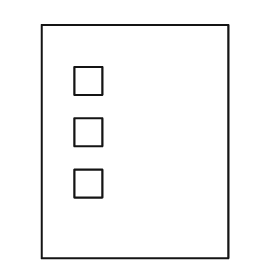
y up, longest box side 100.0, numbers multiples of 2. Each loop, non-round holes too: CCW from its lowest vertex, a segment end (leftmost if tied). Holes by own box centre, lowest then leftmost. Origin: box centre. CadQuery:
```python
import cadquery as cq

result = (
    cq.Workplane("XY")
    .moveTo(-40.0, -50.0)
    .lineTo(40.0, -50.0)
    .lineTo(40.0, 50.0)
    .lineTo(-40.0, 50.0)
    .close()
    .moveTo(-26.0, -24.0)
    .lineTo(-14.0, -24.0)
    .lineTo(-14.0, -12.0)
    .lineTo(-26.0, -12.0)
    .close()
    .moveTo(-26.0, -2.0)
    .lineTo(-14.0, -2.0)
    .lineTo(-14.0, 10.0)
    .lineTo(-26.0, 10.0)
    .close()
    .moveTo(-26.0, 20.0)
    .lineTo(-14.0, 20.0)
    .lineTo(-14.0, 32.0)
    .lineTo(-26.0, 32.0)
    .close()
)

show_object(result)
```